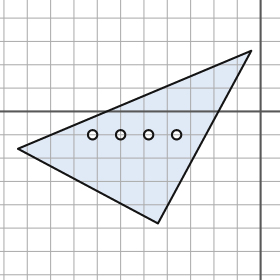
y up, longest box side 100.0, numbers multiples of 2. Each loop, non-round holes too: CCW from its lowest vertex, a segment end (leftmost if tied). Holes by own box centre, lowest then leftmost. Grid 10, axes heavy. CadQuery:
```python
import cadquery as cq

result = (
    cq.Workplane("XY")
    .moveTo(-44.0, -48.0)
    .lineTo(-4.0, 26.0)
    .lineTo(-104.0, -16.0)
    .close()
    .moveTo(-72.0, -10.0)
    .circle(2.0)
    .moveTo(-60.0, -10.0)
    .circle(2.0)
    .moveTo(-48.0, -10.0)
    .circle(2.0)
    .moveTo(-36.0, -10.0)
    .circle(2.0)
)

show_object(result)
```